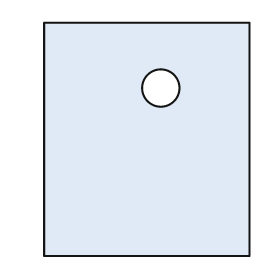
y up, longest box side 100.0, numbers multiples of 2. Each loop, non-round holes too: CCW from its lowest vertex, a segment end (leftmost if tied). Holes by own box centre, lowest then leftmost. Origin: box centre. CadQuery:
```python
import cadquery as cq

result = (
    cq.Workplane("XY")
    .moveTo(-44.0, -50.0)
    .lineTo(44.0, -50.0)
    .lineTo(44.0, 50.0)
    .lineTo(-44.0, 50.0)
    .close()
    .moveTo(6.0, 22.0)
    .circle(8.0)
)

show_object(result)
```